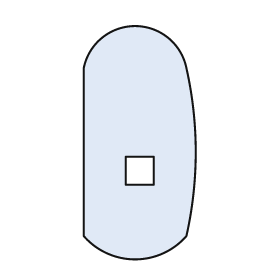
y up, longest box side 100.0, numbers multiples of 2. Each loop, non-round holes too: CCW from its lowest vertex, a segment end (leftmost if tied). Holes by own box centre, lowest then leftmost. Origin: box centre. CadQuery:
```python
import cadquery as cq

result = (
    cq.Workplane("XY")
    .moveTo(-24.0, -40.0)
    .threePointArc((-2.0, -50.0), (20.0, -40.0))
    .threePointArc((24.0, -4.0), (20.0, 32.0))
    .threePointArc((-2.0, 50.0), (-24.0, 32.0))
    .close()
    .moveTo(-6.0, -18.0)
    .lineTo(6.0, -18.0)
    .lineTo(6.0, -6.0)
    .lineTo(-6.0, -6.0)
    .close()
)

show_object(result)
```